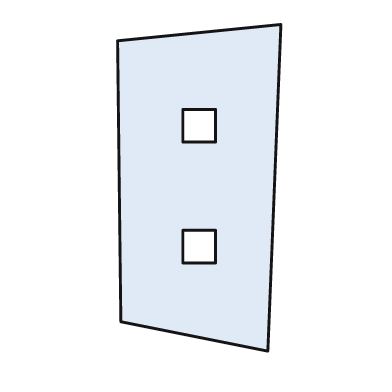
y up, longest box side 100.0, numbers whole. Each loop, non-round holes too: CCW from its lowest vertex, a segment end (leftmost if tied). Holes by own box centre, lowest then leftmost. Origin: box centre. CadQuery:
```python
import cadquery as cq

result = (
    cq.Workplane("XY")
    .moveTo(21.0, -50.0)
    .lineTo(25.0, 50.0)
    .lineTo(-25.0, 45.0)
    .lineTo(-24.0, -41.0)
    .close()
    .moveTo(-5.0, -23.0)
    .lineTo(5.0, -23.0)
    .lineTo(5.0, -13.0)
    .lineTo(-5.0, -13.0)
    .close()
    .moveTo(-5.0, 14.0)
    .lineTo(5.0, 14.0)
    .lineTo(5.0, 24.0)
    .lineTo(-5.0, 24.0)
    .close()
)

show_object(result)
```